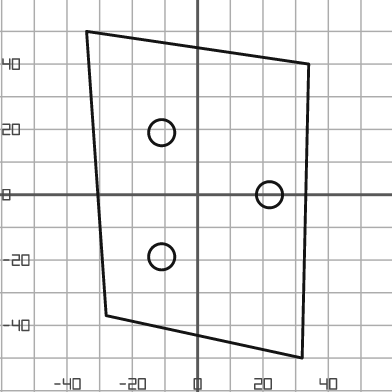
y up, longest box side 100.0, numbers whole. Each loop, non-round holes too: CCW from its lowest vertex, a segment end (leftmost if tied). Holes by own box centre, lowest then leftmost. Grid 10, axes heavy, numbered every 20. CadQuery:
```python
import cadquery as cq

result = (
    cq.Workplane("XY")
    .moveTo(32.0, -50.0)
    .lineTo(34.0, 40.0)
    .lineTo(-34.0, 50.0)
    .lineTo(-28.0, -37.0)
    .close()
    .moveTo(-11.0, -19.0)
    .circle(4.0)
    .moveTo(22.0, 0.0)
    .circle(4.0)
    .moveTo(-11.0, 19.0)
    .circle(4.0)
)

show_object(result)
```